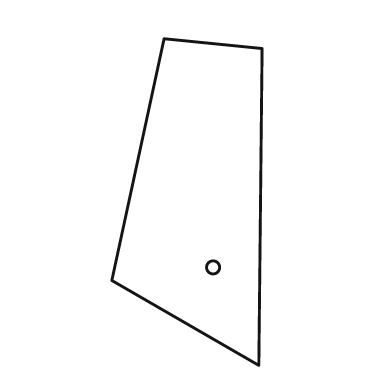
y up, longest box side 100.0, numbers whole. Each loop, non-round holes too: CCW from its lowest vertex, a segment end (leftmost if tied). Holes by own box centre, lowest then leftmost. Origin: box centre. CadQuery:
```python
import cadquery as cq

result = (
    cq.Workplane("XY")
    .moveTo(22.0, -50.0)
    .lineTo(23.0, 47.0)
    .lineTo(-7.0, 50.0)
    .lineTo(-23.0, -24.0)
    .close()
    .moveTo(8.0, -20.0)
    .circle(2.0)
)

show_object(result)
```